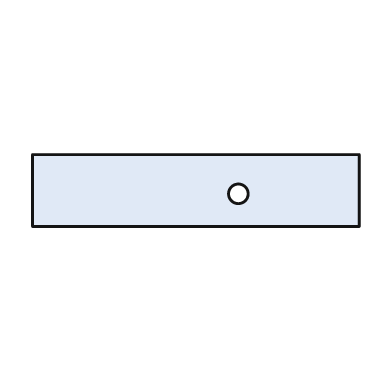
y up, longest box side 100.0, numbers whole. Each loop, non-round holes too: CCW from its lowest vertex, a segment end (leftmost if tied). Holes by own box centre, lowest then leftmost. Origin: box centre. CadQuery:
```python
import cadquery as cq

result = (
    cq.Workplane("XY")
    .moveTo(-50.0, -11.0)
    .lineTo(50.0, -11.0)
    .lineTo(50.0, 11.0)
    .lineTo(-50.0, 11.0)
    .close()
    .moveTo(13.0, -1.0)
    .circle(3.0)
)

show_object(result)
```